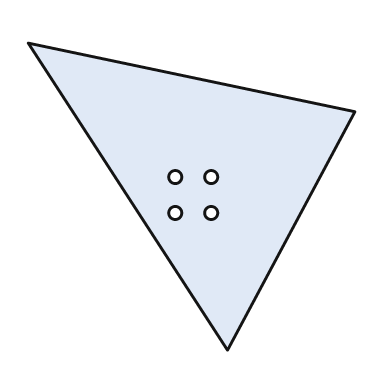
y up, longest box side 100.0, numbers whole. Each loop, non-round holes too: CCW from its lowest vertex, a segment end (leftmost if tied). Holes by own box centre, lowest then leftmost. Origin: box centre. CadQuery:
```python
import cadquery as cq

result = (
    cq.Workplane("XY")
    .moveTo(11.0, -47.0)
    .lineTo(50.0, 26.0)
    .lineTo(-50.0, 47.0)
    .close()
    .moveTo(-5.0, -5.0)
    .circle(2.0)
    .moveTo(6.0, -5.0)
    .circle(2.0)
    .moveTo(-5.0, 6.0)
    .circle(2.0)
    .moveTo(6.0, 6.0)
    .circle(2.0)
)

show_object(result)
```